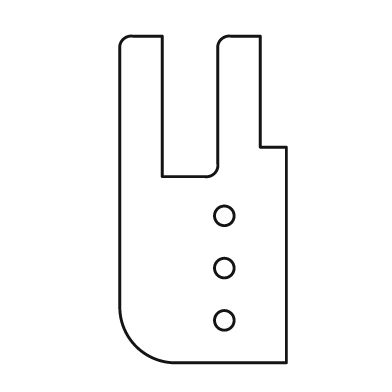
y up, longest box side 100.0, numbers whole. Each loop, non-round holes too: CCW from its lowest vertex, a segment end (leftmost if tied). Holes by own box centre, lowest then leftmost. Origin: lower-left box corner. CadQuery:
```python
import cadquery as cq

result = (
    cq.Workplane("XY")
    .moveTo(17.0, 0.0)
    .lineTo(51.0, 0.0)
    .lineTo(51.0, 66.0)
    .lineTo(43.0, 66.0)
    .lineTo(43.0, 100.0)
    .lineTo(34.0, 100.0)
    .threePointArc((31.0, 99.0), (30.0, 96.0))
    .lineTo(30.0, 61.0)
    .threePointArc((29.0, 58.0), (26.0, 57.0))
    .lineTo(13.0, 57.0)
    .lineTo(13.0, 100.0)
    .lineTo(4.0, 100.0)
    .threePointArc((1.0, 99.0), (0.0, 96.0))
    .lineTo(0.0, 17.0)
    .threePointArc((5.0, 5.0), (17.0, 0.0))
    .close()
    .moveTo(32.0, 13.0)
    .circle(3.0)
    .moveTo(32.0, 29.0)
    .circle(3.0)
    .moveTo(32.0, 45.0)
    .circle(3.0)
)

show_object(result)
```